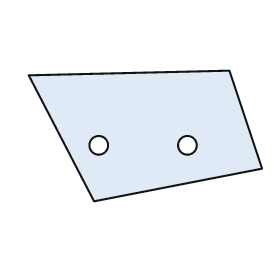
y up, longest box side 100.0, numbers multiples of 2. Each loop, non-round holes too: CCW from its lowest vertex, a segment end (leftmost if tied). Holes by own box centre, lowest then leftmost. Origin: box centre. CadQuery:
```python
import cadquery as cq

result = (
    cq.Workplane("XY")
    .moveTo(-22.0, -28.0)
    .lineTo(50.0, -14.0)
    .lineTo(36.0, 28.0)
    .lineTo(-50.0, 26.0)
    .close()
    .moveTo(-20.0, -4.0)
    .circle(4.0)
    .moveTo(18.0, -4.0)
    .circle(4.0)
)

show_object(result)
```